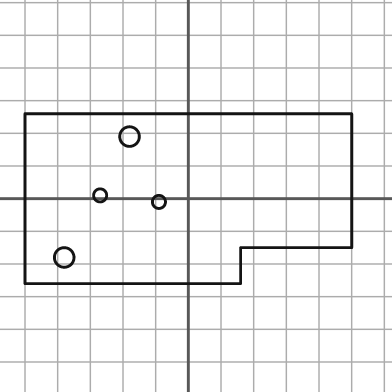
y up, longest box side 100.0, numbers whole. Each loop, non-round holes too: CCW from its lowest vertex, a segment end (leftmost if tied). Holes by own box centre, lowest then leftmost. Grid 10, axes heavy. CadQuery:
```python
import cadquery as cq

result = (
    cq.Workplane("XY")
    .moveTo(-50.0, -26.0)
    .lineTo(16.0, -26.0)
    .lineTo(16.0, -15.0)
    .lineTo(50.0, -15.0)
    .lineTo(50.0, 26.0)
    .lineTo(-50.0, 26.0)
    .close()
    .moveTo(-38.0, -18.0)
    .circle(3.0)
    .moveTo(-9.0, -1.0)
    .circle(2.0)
    .moveTo(-27.0, 1.0)
    .circle(2.0)
    .moveTo(-18.0, 19.0)
    .circle(3.0)
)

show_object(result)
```